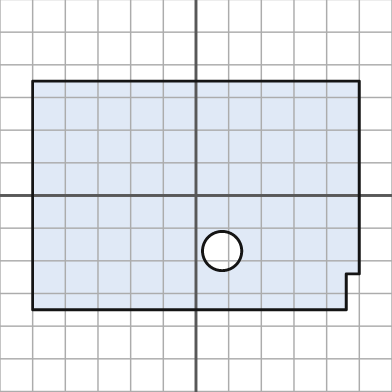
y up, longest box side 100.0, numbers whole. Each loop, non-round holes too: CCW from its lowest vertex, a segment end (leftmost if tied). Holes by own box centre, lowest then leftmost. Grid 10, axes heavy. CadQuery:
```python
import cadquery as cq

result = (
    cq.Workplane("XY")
    .moveTo(-50.0, -35.0)
    .lineTo(46.0, -35.0)
    .lineTo(46.0, -24.0)
    .lineTo(50.0, -24.0)
    .lineTo(50.0, 35.0)
    .lineTo(-50.0, 35.0)
    .close()
    .moveTo(8.0, -17.0)
    .circle(6.0)
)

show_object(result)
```